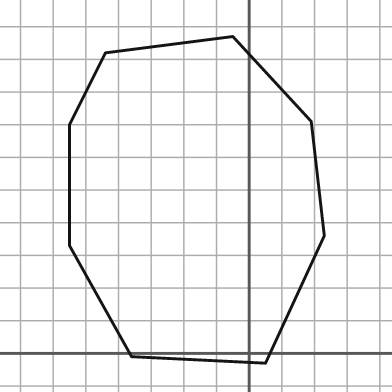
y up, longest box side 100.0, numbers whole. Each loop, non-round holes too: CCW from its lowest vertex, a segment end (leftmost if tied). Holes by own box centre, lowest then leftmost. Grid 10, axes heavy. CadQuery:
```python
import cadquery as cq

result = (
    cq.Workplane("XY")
    .moveTo(5.0, -3.0)
    .lineTo(23.0, 36.0)
    .lineTo(19.0, 71.0)
    .lineTo(-5.0, 97.0)
    .lineTo(-44.0, 92.0)
    .lineTo(-55.0, 70.0)
    .lineTo(-55.0, 33.0)
    .lineTo(-36.0, -1.0)
    .close()
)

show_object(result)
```